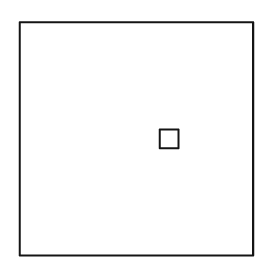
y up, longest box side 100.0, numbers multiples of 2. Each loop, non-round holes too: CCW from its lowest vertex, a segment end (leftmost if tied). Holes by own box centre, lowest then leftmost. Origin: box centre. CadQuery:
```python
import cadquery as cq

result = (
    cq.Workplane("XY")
    .moveTo(-50.0, -50.0)
    .lineTo(50.0, -50.0)
    .lineTo(50.0, 50.0)
    .lineTo(-50.0, 50.0)
    .close()
    .moveTo(10.0, -4.0)
    .lineTo(18.0, -4.0)
    .lineTo(18.0, 4.0)
    .lineTo(10.0, 4.0)
    .close()
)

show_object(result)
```